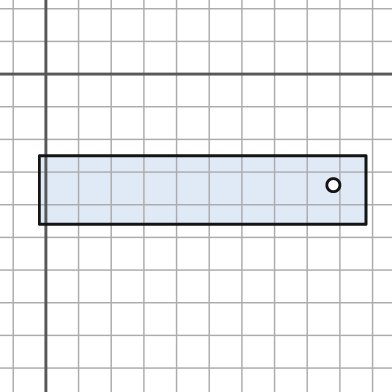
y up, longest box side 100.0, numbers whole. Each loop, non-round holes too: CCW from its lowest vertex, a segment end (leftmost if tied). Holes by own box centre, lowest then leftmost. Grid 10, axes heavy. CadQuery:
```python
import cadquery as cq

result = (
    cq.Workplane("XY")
    .moveTo(-2.0, -46.0)
    .lineTo(98.0, -46.0)
    .lineTo(98.0, -25.0)
    .lineTo(-2.0, -25.0)
    .close()
    .moveTo(88.0, -34.0)
    .circle(2.0)
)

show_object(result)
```